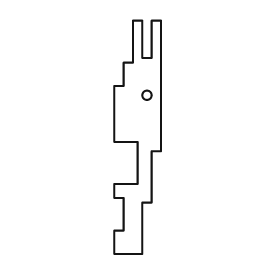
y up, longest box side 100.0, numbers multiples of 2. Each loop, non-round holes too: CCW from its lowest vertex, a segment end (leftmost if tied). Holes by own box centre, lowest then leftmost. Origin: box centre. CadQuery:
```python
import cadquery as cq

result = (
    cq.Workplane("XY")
    .moveTo(-10.0, -50.0)
    .lineTo(2.0, -50.0)
    .lineTo(2.0, -28.0)
    .lineTo(6.0, -28.0)
    .lineTo(6.0, -6.0)
    .lineTo(10.0, -6.0)
    .lineTo(10.0, 50.0)
    .lineTo(6.0, 50.0)
    .lineTo(6.0, 34.0)
    .lineTo(2.0, 34.0)
    .lineTo(2.0, 50.0)
    .lineTo(-2.0, 50.0)
    .lineTo(-2.0, 32.0)
    .lineTo(-6.0, 32.0)
    .lineTo(-6.0, 22.0)
    .lineTo(-10.0, 22.0)
    .lineTo(-10.0, -2.0)
    .lineTo(0.0, -2.0)
    .lineTo(0.0, -20.0)
    .lineTo(-10.0, -20.0)
    .lineTo(-10.0, -26.0)
    .lineTo(-6.0, -26.0)
    .lineTo(-6.0, -40.0)
    .lineTo(-10.0, -40.0)
    .close()
    .moveTo(4.0, 18.0)
    .circle(2.0)
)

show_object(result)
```